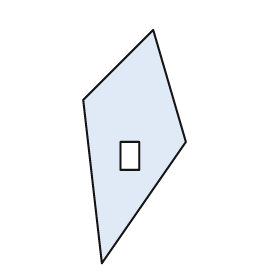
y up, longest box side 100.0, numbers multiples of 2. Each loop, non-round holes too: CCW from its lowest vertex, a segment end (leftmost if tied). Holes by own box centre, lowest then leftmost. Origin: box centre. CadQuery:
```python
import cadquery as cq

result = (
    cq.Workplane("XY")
    .moveTo(-14.0, -50.0)
    .lineTo(22.0, 2.0)
    .lineTo(8.0, 50.0)
    .lineTo(-22.0, 20.0)
    .close()
    .moveTo(-6.0, -10.0)
    .lineTo(2.0, -10.0)
    .lineTo(2.0, 2.0)
    .lineTo(-6.0, 2.0)
    .close()
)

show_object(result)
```